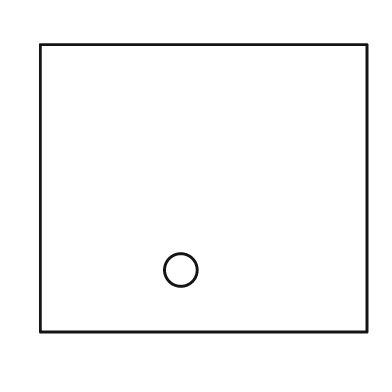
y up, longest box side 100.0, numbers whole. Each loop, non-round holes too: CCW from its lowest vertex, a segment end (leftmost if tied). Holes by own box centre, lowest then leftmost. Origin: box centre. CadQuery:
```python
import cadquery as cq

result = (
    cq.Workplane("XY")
    .moveTo(-50.0, -44.0)
    .lineTo(50.0, -44.0)
    .lineTo(50.0, 44.0)
    .lineTo(-50.0, 44.0)
    .close()
    .moveTo(-7.0, -25.0)
    .circle(5.0)
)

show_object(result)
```